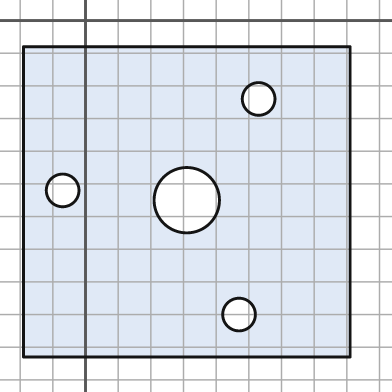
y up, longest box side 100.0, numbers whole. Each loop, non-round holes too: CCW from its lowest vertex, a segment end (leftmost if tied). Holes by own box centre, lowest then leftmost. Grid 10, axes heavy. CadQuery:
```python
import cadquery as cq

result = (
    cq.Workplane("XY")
    .moveTo(-19.0, -103.0)
    .lineTo(81.0, -103.0)
    .lineTo(81.0, -8.0)
    .lineTo(-19.0, -8.0)
    .close()
    .moveTo(47.0, -90.0)
    .circle(5.0)
    .moveTo(31.0, -55.0)
    .circle(10.0)
    .moveTo(-7.0, -52.0)
    .circle(5.0)
    .moveTo(53.0, -24.0)
    .circle(5.0)
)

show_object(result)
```